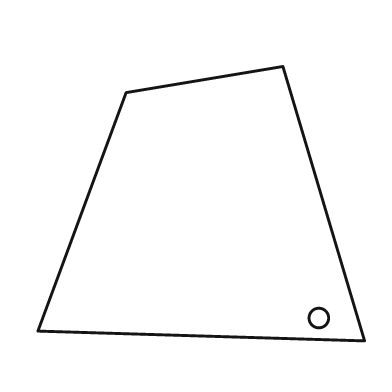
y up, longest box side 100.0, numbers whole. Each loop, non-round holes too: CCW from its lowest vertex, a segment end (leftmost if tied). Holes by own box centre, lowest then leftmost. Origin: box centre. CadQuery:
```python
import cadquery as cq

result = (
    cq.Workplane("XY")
    .moveTo(50.0, -42.0)
    .lineTo(25.0, 42.0)
    .lineTo(-23.0, 34.0)
    .lineTo(-50.0, -39.0)
    .close()
    .moveTo(36.0, -35.0)
    .circle(3.0)
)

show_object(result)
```